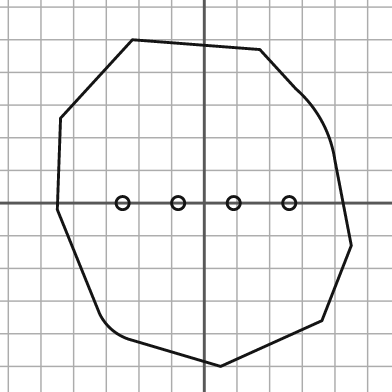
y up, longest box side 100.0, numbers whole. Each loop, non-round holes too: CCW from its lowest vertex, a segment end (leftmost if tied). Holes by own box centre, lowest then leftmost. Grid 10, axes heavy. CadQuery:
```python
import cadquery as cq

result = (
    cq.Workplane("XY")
    .moveTo(5.0, -50.0)
    .lineTo(36.0, -36.0)
    .lineTo(45.0, -13.0)
    .lineTo(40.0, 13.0)
    .threePointArc((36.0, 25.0), (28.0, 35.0))
    .lineTo(17.0, 47.0)
    .lineTo(-22.0, 50.0)
    .lineTo(-44.0, 26.0)
    .lineTo(-45.0, -2.0)
    .lineTo(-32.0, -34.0)
    .threePointArc((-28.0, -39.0), (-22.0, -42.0))
    .close()
    .moveTo(-25.0, 0.0)
    .circle(2.0)
    .moveTo(-8.0, 0.0)
    .circle(2.0)
    .moveTo(9.0, 0.0)
    .circle(2.0)
    .moveTo(26.0, 0.0)
    .circle(2.0)
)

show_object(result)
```